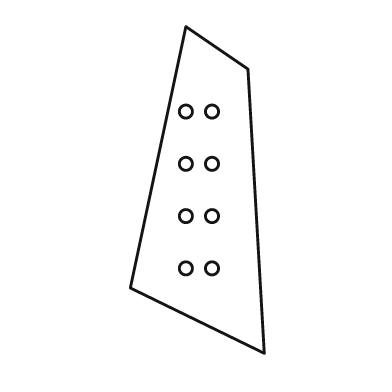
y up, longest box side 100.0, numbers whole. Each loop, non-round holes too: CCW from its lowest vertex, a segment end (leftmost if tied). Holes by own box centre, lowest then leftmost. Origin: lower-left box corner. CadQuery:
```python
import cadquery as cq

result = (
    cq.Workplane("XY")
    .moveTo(41.0, 0.0)
    .lineTo(36.0, 87.0)
    .lineTo(17.0, 100.0)
    .lineTo(0.0, 20.0)
    .close()
    .moveTo(17.0, 26.0)
    .circle(2.0)
    .moveTo(25.0, 26.0)
    .circle(2.0)
    .moveTo(17.0, 42.0)
    .circle(2.0)
    .moveTo(25.0, 42.0)
    .circle(2.0)
    .moveTo(17.0, 58.0)
    .circle(2.0)
    .moveTo(25.0, 58.0)
    .circle(2.0)
    .moveTo(17.0, 74.0)
    .circle(2.0)
    .moveTo(25.0, 74.0)
    .circle(2.0)
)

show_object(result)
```